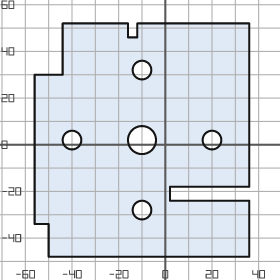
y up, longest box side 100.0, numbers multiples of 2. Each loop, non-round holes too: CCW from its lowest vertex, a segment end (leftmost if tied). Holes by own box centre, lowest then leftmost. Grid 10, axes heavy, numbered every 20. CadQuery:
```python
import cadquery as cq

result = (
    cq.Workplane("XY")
    .moveTo(-50.0, -48.0)
    .lineTo(36.0, -48.0)
    .lineTo(36.0, -24.0)
    .lineTo(2.0, -24.0)
    .lineTo(2.0, -18.0)
    .lineTo(36.0, -18.0)
    .lineTo(36.0, 52.0)
    .lineTo(-12.0, 52.0)
    .lineTo(-12.0, 46.0)
    .lineTo(-16.0, 46.0)
    .lineTo(-16.0, 52.0)
    .lineTo(-44.0, 52.0)
    .lineTo(-44.0, 30.0)
    .lineTo(-56.0, 30.0)
    .lineTo(-56.0, -34.0)
    .lineTo(-50.0, -34.0)
    .close()
    .moveTo(-10.0, -28.0)
    .circle(4.0)
    .moveTo(-40.0, 2.0)
    .circle(4.0)
    .moveTo(-10.0, 2.0)
    .circle(6.0)
    .moveTo(20.0, 2.0)
    .circle(4.0)
    .moveTo(-10.0, 32.0)
    .circle(4.0)
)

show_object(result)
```